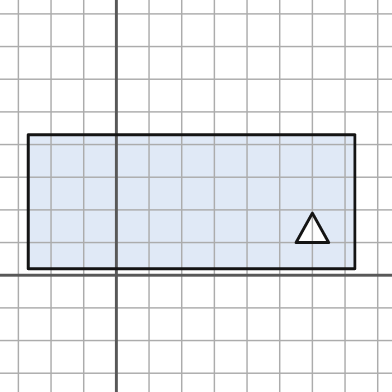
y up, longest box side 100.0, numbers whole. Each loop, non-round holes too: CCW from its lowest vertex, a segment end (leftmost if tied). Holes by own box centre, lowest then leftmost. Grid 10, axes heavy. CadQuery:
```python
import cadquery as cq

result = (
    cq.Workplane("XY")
    .moveTo(-27.0, 2.0)
    .lineTo(73.0, 2.0)
    .lineTo(73.0, 43.0)
    .lineTo(-27.0, 43.0)
    .close()
    .moveTo(55.0, 10.0)
    .lineTo(65.0, 10.0)
    .lineTo(60.0, 19.0)
    .close()
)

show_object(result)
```